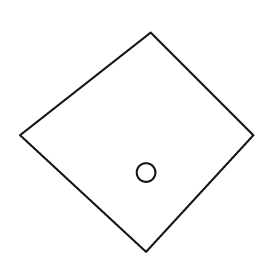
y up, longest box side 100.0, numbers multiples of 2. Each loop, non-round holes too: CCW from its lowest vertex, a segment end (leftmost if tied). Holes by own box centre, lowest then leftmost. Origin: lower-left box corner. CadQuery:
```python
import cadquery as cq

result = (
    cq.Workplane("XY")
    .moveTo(54.0, 0.0)
    .lineTo(100.0, 50.0)
    .lineTo(56.0, 94.0)
    .lineTo(0.0, 50.0)
    .close()
    .moveTo(54.0, 34.0)
    .circle(4.0)
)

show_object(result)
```